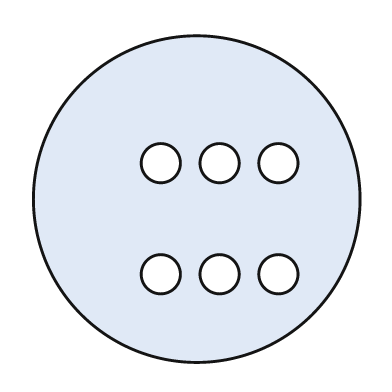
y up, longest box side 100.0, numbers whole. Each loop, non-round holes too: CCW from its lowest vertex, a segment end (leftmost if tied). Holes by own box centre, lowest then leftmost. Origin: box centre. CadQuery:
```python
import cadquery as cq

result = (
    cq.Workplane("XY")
    .moveTo(0.0, 0.0)
    .circle(50.0)
    .moveTo(-11.0, -23.0)
    .circle(6.0)
    .moveTo(7.0, -23.0)
    .circle(6.0)
    .moveTo(25.0, -23.0)
    .circle(6.0)
    .moveTo(-11.0, 11.0)
    .circle(6.0)
    .moveTo(7.0, 11.0)
    .circle(6.0)
    .moveTo(25.0, 11.0)
    .circle(6.0)
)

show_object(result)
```